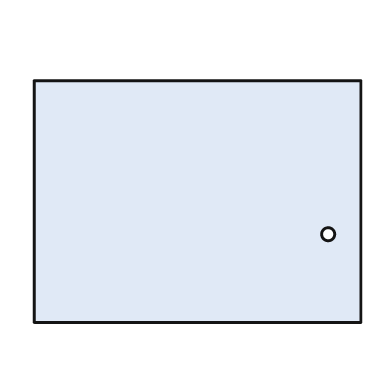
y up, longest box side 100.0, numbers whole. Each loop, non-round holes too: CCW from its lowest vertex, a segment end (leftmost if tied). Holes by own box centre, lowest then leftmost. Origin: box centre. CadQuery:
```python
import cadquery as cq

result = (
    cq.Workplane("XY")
    .moveTo(-50.0, -37.0)
    .lineTo(50.0, -37.0)
    .lineTo(50.0, 37.0)
    .lineTo(-50.0, 37.0)
    .close()
    .moveTo(40.0, -10.0)
    .circle(2.0)
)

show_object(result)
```